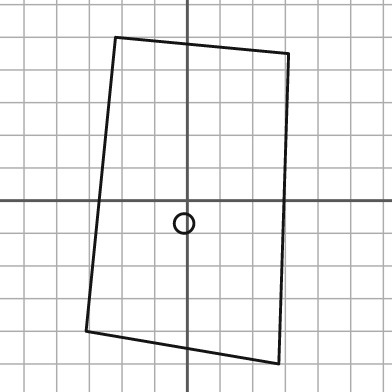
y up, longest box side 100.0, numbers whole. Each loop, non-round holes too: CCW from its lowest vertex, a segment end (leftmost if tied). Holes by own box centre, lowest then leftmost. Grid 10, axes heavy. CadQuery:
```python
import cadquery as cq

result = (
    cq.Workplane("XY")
    .moveTo(28.0, -50.0)
    .lineTo(31.0, 45.0)
    .lineTo(-22.0, 50.0)
    .lineTo(-31.0, -40.0)
    .close()
    .moveTo(-1.0, -7.0)
    .circle(3.0)
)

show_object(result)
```